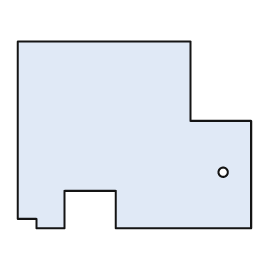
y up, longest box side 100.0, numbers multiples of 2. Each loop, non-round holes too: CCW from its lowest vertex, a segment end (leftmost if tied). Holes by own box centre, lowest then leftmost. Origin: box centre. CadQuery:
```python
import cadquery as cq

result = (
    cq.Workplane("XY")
    .moveTo(-42.0, -40.0)
    .lineTo(-30.0, -40.0)
    .lineTo(-30.0, -24.0)
    .lineTo(-8.0, -24.0)
    .lineTo(-8.0, -40.0)
    .lineTo(50.0, -40.0)
    .lineTo(50.0, 6.0)
    .lineTo(24.0, 6.0)
    .lineTo(24.0, 40.0)
    .lineTo(-50.0, 40.0)
    .lineTo(-50.0, -36.0)
    .lineTo(-42.0, -36.0)
    .close()
    .moveTo(38.0, -16.0)
    .circle(2.0)
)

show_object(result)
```